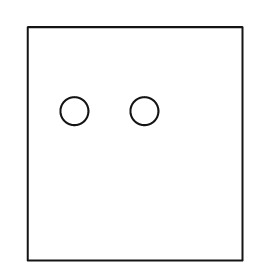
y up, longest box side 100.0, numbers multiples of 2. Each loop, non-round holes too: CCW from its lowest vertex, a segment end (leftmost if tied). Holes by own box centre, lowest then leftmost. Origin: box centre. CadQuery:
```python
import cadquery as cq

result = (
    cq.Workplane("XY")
    .moveTo(-46.0, -50.0)
    .lineTo(46.0, -50.0)
    .lineTo(46.0, 50.0)
    .lineTo(-46.0, 50.0)
    .close()
    .moveTo(-26.0, 14.0)
    .circle(6.0)
    .moveTo(4.0, 14.0)
    .circle(6.0)
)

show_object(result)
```